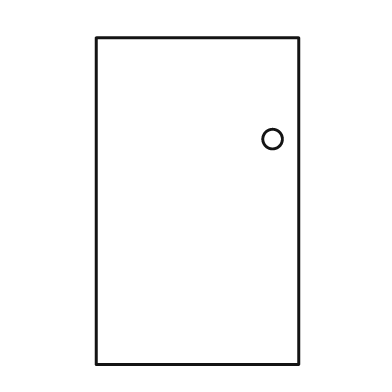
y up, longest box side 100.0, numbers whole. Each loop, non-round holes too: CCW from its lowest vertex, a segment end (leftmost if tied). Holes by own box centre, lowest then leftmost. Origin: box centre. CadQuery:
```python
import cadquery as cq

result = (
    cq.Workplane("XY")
    .moveTo(-31.0, -50.0)
    .lineTo(31.0, -50.0)
    .lineTo(31.0, 50.0)
    .lineTo(-31.0, 50.0)
    .close()
    .moveTo(23.0, 19.0)
    .circle(3.0)
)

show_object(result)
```